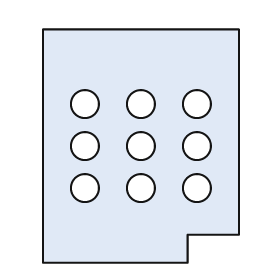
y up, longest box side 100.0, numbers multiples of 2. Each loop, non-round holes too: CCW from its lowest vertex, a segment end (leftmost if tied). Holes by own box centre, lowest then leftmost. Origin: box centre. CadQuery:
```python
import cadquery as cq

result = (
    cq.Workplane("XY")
    .moveTo(-42.0, -50.0)
    .lineTo(20.0, -50.0)
    .lineTo(20.0, -38.0)
    .lineTo(42.0, -38.0)
    .lineTo(42.0, 50.0)
    .lineTo(-42.0, 50.0)
    .close()
    .moveTo(-24.0, -18.0)
    .circle(6.0)
    .moveTo(0.0, -18.0)
    .circle(6.0)
    .moveTo(24.0, -18.0)
    .circle(6.0)
    .moveTo(-24.0, 0.0)
    .circle(6.0)
    .moveTo(0.0, 0.0)
    .circle(6.0)
    .moveTo(24.0, 0.0)
    .circle(6.0)
    .moveTo(-24.0, 18.0)
    .circle(6.0)
    .moveTo(0.0, 18.0)
    .circle(6.0)
    .moveTo(24.0, 18.0)
    .circle(6.0)
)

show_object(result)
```